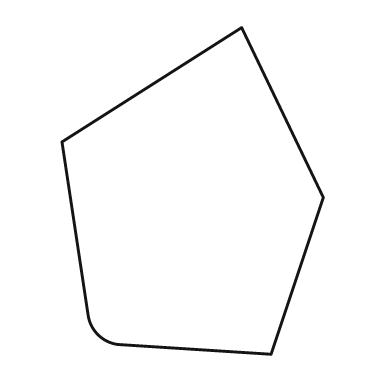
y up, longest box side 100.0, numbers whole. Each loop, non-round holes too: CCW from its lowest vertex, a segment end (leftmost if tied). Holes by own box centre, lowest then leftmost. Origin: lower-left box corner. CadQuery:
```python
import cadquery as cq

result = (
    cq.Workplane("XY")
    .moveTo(64.0, 0.0)
    .lineTo(80.0, 48.0)
    .lineTo(55.0, 100.0)
    .lineTo(0.0, 65.0)
    .lineTo(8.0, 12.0)
    .threePointArc((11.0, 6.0), (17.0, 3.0))
    .close()
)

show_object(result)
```